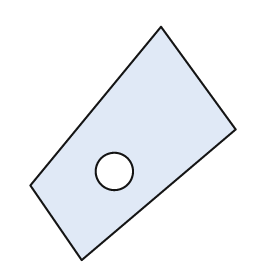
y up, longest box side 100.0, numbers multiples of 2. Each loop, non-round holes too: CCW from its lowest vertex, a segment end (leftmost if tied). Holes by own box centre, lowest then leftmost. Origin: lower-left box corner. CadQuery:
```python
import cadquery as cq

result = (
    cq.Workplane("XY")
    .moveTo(22.0, 0.0)
    .lineTo(88.0, 56.0)
    .lineTo(56.0, 100.0)
    .lineTo(0.0, 32.0)
    .close()
    .moveTo(36.0, 38.0)
    .circle(8.0)
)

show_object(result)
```